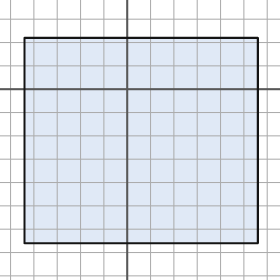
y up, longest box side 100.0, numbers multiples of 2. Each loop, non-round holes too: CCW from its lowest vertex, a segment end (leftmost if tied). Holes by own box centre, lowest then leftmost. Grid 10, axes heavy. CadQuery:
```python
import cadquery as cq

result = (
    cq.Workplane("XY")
    .moveTo(-44.0, -66.0)
    .lineTo(56.0, -66.0)
    .lineTo(56.0, 22.0)
    .lineTo(-44.0, 22.0)
    .close()
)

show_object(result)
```